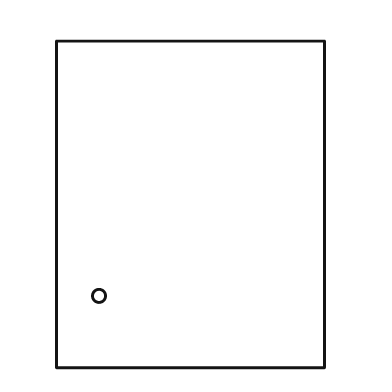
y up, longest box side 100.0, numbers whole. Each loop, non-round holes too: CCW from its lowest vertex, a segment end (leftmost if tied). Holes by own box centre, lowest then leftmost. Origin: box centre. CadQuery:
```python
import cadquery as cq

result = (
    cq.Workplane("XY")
    .moveTo(-41.0, -50.0)
    .lineTo(41.0, -50.0)
    .lineTo(41.0, 50.0)
    .lineTo(-41.0, 50.0)
    .close()
    .moveTo(-28.0, -28.0)
    .circle(2.0)
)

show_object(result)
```